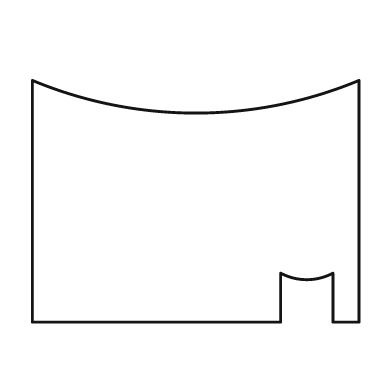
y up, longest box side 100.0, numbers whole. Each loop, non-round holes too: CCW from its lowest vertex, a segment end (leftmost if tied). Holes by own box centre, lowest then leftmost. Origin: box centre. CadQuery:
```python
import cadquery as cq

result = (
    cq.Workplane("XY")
    .moveTo(-50.0, -37.0)
    .lineTo(26.0, -37.0)
    .lineTo(26.0, -22.0)
    .threePointArc((34.0, -24.0), (42.0, -22.0))
    .lineTo(42.0, -37.0)
    .lineTo(50.0, -37.0)
    .lineTo(50.0, 37.0)
    .threePointArc((0.0, 27.0), (-50.0, 37.0))
    .close()
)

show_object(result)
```